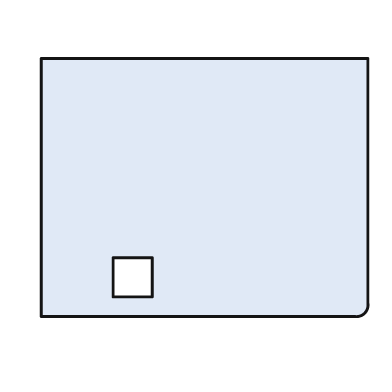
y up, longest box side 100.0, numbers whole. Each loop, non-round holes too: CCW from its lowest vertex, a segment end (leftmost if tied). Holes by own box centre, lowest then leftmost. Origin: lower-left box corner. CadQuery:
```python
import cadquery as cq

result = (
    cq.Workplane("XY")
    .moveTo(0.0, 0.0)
    .lineTo(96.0, 0.0)
    .threePointArc((99.0, 1.0), (100.0, 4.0))
    .lineTo(100.0, 79.0)
    .lineTo(0.0, 79.0)
    .close()
    .moveTo(22.0, 6.0)
    .lineTo(34.0, 6.0)
    .lineTo(34.0, 18.0)
    .lineTo(22.0, 18.0)
    .close()
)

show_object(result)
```